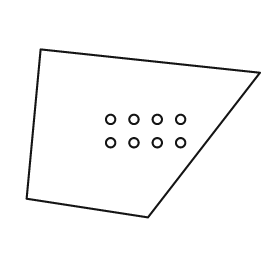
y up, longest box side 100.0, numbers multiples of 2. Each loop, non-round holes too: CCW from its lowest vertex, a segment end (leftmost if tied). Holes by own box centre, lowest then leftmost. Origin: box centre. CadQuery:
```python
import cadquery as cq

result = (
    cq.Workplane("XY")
    .moveTo(2.0, -36.0)
    .lineTo(50.0, 26.0)
    .lineTo(-44.0, 36.0)
    .lineTo(-50.0, -28.0)
    .close()
    .moveTo(-14.0, -4.0)
    .circle(2.0)
    .moveTo(-4.0, -4.0)
    .circle(2.0)
    .moveTo(6.0, -4.0)
    .circle(2.0)
    .moveTo(16.0, -4.0)
    .circle(2.0)
    .moveTo(-14.0, 6.0)
    .circle(2.0)
    .moveTo(-4.0, 6.0)
    .circle(2.0)
    .moveTo(6.0, 6.0)
    .circle(2.0)
    .moveTo(16.0, 6.0)
    .circle(2.0)
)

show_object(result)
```